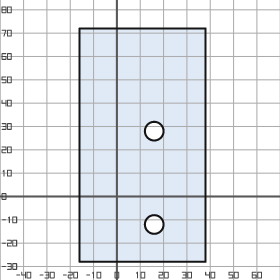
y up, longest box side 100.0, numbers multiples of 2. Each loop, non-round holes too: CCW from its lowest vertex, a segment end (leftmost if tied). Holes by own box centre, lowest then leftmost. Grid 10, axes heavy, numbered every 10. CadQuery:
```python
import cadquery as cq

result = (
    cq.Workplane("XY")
    .moveTo(-16.0, -28.0)
    .lineTo(38.0, -28.0)
    .lineTo(38.0, 72.0)
    .lineTo(-16.0, 72.0)
    .close()
    .moveTo(16.0, -12.0)
    .circle(4.0)
    .moveTo(16.0, 28.0)
    .circle(4.0)
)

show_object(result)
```